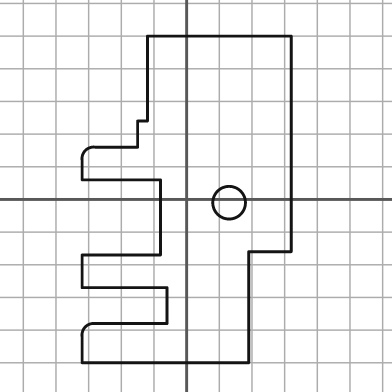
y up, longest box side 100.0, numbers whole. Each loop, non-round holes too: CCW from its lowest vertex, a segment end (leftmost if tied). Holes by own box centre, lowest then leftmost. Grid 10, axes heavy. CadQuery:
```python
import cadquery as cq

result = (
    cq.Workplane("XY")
    .moveTo(-32.0, -50.0)
    .lineTo(19.0, -50.0)
    .lineTo(19.0, -16.0)
    .lineTo(32.0, -16.0)
    .lineTo(32.0, 50.0)
    .lineTo(-12.0, 50.0)
    .lineTo(-12.0, 24.0)
    .lineTo(-15.0, 24.0)
    .lineTo(-15.0, 16.0)
    .lineTo(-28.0, 16.0)
    .threePointArc((-31.0, 15.0), (-32.0, 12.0))
    .lineTo(-32.0, 6.0)
    .lineTo(-8.0, 6.0)
    .lineTo(-8.0, -17.0)
    .lineTo(-32.0, -17.0)
    .lineTo(-32.0, -27.0)
    .lineTo(-6.0, -27.0)
    .lineTo(-6.0, -38.0)
    .lineTo(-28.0, -38.0)
    .threePointArc((-31.0, -39.0), (-32.0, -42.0))
    .close()
    .moveTo(13.0, -1.0)
    .circle(5.0)
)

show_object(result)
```